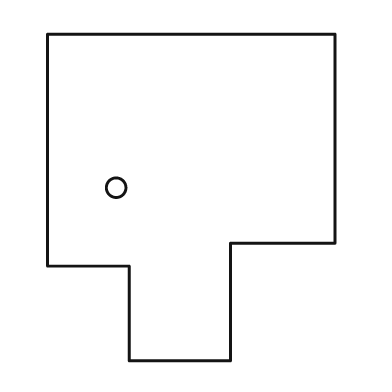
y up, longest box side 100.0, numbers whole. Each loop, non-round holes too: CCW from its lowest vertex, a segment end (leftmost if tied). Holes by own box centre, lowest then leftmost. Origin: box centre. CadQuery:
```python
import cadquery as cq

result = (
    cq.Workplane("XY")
    .moveTo(-19.0, -50.0)
    .lineTo(12.0, -50.0)
    .lineTo(12.0, -14.0)
    .lineTo(44.0, -14.0)
    .lineTo(44.0, 50.0)
    .lineTo(-44.0, 50.0)
    .lineTo(-44.0, -21.0)
    .lineTo(-19.0, -21.0)
    .close()
    .moveTo(-23.0, 3.0)
    .circle(3.0)
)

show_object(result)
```